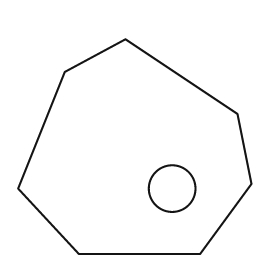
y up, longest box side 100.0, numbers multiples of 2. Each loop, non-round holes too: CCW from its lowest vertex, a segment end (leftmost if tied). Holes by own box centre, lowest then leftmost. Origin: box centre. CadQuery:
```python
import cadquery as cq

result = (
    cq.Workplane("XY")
    .moveTo(-24.0, -46.0)
    .lineTo(28.0, -46.0)
    .lineTo(50.0, -16.0)
    .lineTo(44.0, 14.0)
    .lineTo(-4.0, 46.0)
    .lineTo(-30.0, 32.0)
    .lineTo(-50.0, -18.0)
    .close()
    .moveTo(16.0, -18.0)
    .circle(10.0)
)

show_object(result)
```